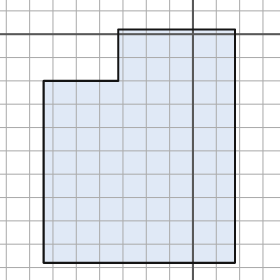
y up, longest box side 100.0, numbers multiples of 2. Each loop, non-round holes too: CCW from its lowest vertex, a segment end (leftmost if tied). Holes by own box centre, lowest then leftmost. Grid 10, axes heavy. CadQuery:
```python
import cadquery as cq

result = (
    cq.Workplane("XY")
    .moveTo(-64.0, -98.0)
    .lineTo(18.0, -98.0)
    .lineTo(18.0, 2.0)
    .lineTo(-32.0, 2.0)
    .lineTo(-32.0, -20.0)
    .lineTo(-64.0, -20.0)
    .close()
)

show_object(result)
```